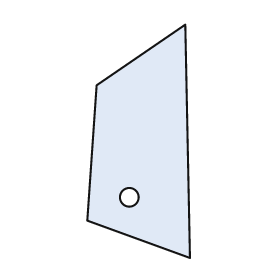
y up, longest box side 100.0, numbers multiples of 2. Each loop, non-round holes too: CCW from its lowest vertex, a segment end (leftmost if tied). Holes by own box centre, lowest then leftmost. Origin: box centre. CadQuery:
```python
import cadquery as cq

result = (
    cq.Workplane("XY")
    .moveTo(22.0, -50.0)
    .lineTo(20.0, 50.0)
    .lineTo(-18.0, 24.0)
    .lineTo(-22.0, -34.0)
    .close()
    .moveTo(-4.0, -24.0)
    .circle(4.0)
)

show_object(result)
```